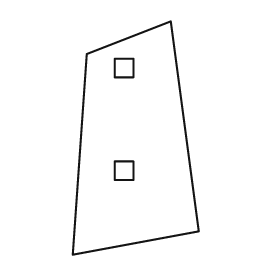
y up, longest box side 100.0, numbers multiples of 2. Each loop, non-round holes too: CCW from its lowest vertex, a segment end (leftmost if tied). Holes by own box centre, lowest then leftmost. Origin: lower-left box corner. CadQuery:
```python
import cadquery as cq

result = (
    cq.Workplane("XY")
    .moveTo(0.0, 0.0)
    .lineTo(54.0, 10.0)
    .lineTo(42.0, 100.0)
    .lineTo(6.0, 86.0)
    .close()
    .moveTo(18.0, 32.0)
    .lineTo(26.0, 32.0)
    .lineTo(26.0, 40.0)
    .lineTo(18.0, 40.0)
    .close()
    .moveTo(18.0, 76.0)
    .lineTo(26.0, 76.0)
    .lineTo(26.0, 84.0)
    .lineTo(18.0, 84.0)
    .close()
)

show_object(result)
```